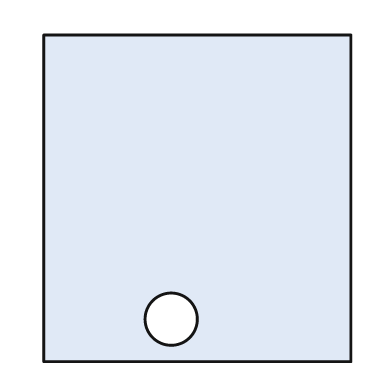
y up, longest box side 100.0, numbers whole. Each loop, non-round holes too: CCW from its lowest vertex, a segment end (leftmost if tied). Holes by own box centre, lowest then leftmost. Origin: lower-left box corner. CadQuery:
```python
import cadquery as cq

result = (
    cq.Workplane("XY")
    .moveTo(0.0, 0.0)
    .lineTo(94.0, 0.0)
    .lineTo(94.0, 100.0)
    .lineTo(0.0, 100.0)
    .close()
    .moveTo(39.0, 13.0)
    .circle(8.0)
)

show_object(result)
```